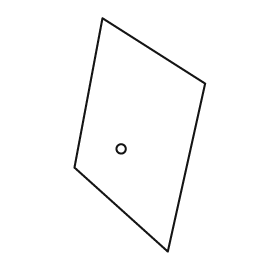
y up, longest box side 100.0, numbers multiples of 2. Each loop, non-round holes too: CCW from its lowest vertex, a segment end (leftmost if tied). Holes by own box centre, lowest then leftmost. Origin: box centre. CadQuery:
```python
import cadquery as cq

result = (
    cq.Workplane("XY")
    .moveTo(12.0, -50.0)
    .lineTo(28.0, 22.0)
    .lineTo(-16.0, 50.0)
    .lineTo(-28.0, -14.0)
    .close()
    .moveTo(-8.0, -6.0)
    .circle(2.0)
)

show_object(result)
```